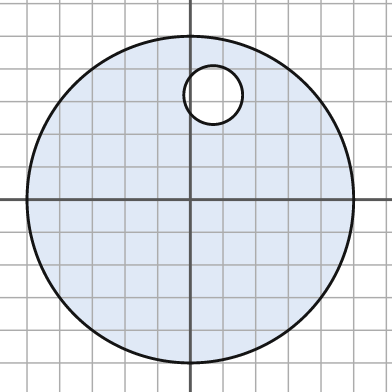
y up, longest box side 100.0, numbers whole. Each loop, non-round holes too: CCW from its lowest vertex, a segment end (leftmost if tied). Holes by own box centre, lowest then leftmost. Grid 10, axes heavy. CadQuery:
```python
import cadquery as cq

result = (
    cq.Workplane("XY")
    .moveTo(0.0, 0.0)
    .circle(50.0)
    .moveTo(7.0, 32.0)
    .circle(9.0)
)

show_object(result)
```